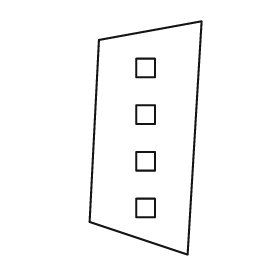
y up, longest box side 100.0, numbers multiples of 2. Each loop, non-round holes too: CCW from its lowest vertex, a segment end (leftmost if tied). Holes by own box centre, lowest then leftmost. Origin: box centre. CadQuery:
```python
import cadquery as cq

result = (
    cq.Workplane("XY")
    .moveTo(18.0, -50.0)
    .lineTo(24.0, 50.0)
    .lineTo(-20.0, 42.0)
    .lineTo(-24.0, -36.0)
    .close()
    .moveTo(-4.0, -34.0)
    .lineTo(4.0, -34.0)
    .lineTo(4.0, -26.0)
    .lineTo(-4.0, -26.0)
    .close()
    .moveTo(-4.0, -14.0)
    .lineTo(4.0, -14.0)
    .lineTo(4.0, -6.0)
    .lineTo(-4.0, -6.0)
    .close()
    .moveTo(-4.0, 6.0)
    .lineTo(4.0, 6.0)
    .lineTo(4.0, 14.0)
    .lineTo(-4.0, 14.0)
    .close()
    .moveTo(-4.0, 26.0)
    .lineTo(4.0, 26.0)
    .lineTo(4.0, 34.0)
    .lineTo(-4.0, 34.0)
    .close()
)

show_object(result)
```